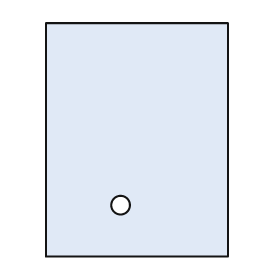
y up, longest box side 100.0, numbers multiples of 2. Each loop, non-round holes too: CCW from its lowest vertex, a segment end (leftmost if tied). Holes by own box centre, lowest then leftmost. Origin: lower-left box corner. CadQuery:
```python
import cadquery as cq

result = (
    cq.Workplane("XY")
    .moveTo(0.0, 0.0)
    .lineTo(78.0, 0.0)
    .lineTo(78.0, 100.0)
    .lineTo(0.0, 100.0)
    .close()
    .moveTo(32.0, 22.0)
    .circle(4.0)
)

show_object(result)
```